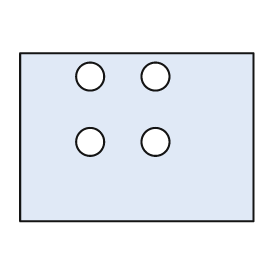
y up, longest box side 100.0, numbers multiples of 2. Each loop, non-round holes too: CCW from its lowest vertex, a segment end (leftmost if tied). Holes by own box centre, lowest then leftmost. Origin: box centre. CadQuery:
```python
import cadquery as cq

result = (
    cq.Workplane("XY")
    .moveTo(-50.0, -36.0)
    .lineTo(50.0, -36.0)
    .lineTo(50.0, 36.0)
    .lineTo(-50.0, 36.0)
    .close()
    .moveTo(-20.0, -2.0)
    .circle(6.0)
    .moveTo(8.0, -2.0)
    .circle(6.0)
    .moveTo(-20.0, 26.0)
    .circle(6.0)
    .moveTo(8.0, 26.0)
    .circle(6.0)
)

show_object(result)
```